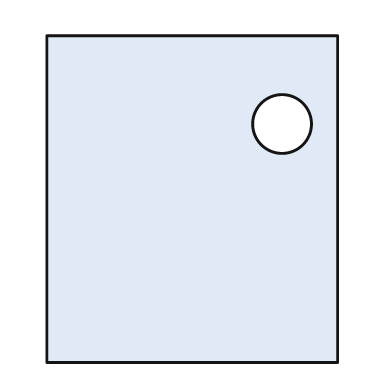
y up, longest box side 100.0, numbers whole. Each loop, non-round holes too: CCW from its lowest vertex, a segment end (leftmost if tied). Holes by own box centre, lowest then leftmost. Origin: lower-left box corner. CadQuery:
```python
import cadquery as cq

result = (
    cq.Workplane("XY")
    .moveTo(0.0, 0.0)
    .lineTo(89.0, 0.0)
    .lineTo(89.0, 100.0)
    .lineTo(0.0, 100.0)
    .close()
    .moveTo(72.0, 73.0)
    .circle(9.0)
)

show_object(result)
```